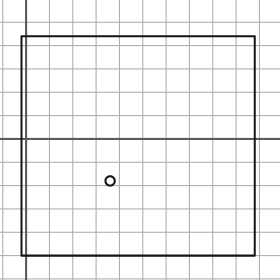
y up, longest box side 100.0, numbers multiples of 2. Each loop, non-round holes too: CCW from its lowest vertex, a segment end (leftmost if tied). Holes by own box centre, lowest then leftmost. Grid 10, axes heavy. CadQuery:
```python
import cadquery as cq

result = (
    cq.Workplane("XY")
    .moveTo(-2.0, -50.0)
    .lineTo(98.0, -50.0)
    .lineTo(98.0, 44.0)
    .lineTo(-2.0, 44.0)
    .close()
    .moveTo(36.0, -18.0)
    .circle(2.0)
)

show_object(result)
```